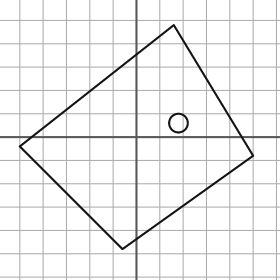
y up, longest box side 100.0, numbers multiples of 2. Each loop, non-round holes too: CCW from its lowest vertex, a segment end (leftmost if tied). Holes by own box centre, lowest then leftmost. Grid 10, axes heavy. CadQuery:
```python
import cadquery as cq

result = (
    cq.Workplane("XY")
    .moveTo(-6.0, -48.0)
    .lineTo(50.0, -8.0)
    .lineTo(16.0, 48.0)
    .lineTo(-50.0, -4.0)
    .close()
    .moveTo(18.0, 6.0)
    .circle(4.0)
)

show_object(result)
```